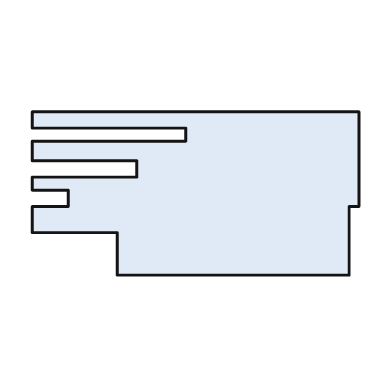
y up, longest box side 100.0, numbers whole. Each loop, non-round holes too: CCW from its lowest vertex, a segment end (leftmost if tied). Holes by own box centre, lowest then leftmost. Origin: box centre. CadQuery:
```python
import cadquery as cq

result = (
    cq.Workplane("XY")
    .moveTo(-24.0, -25.0)
    .lineTo(47.0, -25.0)
    .lineTo(47.0, -4.0)
    .lineTo(50.0, -4.0)
    .lineTo(50.0, 25.0)
    .lineTo(-50.0, 25.0)
    .lineTo(-50.0, 20.0)
    .lineTo(-3.0, 20.0)
    .lineTo(-3.0, 16.0)
    .lineTo(-50.0, 16.0)
    .lineTo(-50.0, 10.0)
    .lineTo(-18.0, 10.0)
    .lineTo(-18.0, 5.0)
    .lineTo(-50.0, 5.0)
    .lineTo(-50.0, 1.0)
    .lineTo(-39.0, 1.0)
    .lineTo(-39.0, -4.0)
    .lineTo(-50.0, -4.0)
    .lineTo(-50.0, -12.0)
    .lineTo(-24.0, -12.0)
    .close()
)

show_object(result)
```